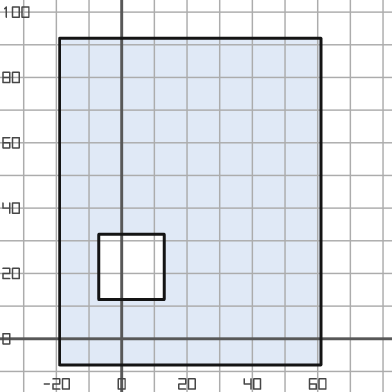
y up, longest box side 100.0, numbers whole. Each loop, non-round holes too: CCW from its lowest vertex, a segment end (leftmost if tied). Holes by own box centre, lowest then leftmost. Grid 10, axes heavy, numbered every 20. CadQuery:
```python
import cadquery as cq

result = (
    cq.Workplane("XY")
    .moveTo(-19.0, -8.0)
    .lineTo(61.0, -8.0)
    .lineTo(61.0, 92.0)
    .lineTo(-19.0, 92.0)
    .close()
    .moveTo(-7.0, 12.0)
    .lineTo(13.0, 12.0)
    .lineTo(13.0, 32.0)
    .lineTo(-7.0, 32.0)
    .close()
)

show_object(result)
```